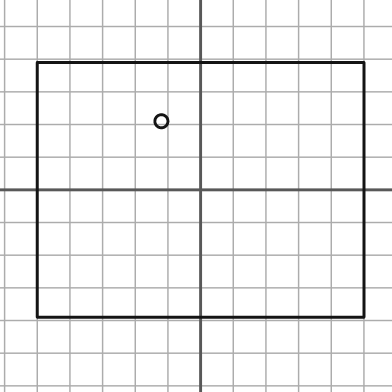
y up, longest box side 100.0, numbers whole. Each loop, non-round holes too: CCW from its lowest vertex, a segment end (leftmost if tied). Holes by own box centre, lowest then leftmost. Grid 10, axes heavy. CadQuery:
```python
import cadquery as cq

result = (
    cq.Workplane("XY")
    .moveTo(-50.0, -39.0)
    .lineTo(50.0, -39.0)
    .lineTo(50.0, 39.0)
    .lineTo(-50.0, 39.0)
    .close()
    .moveTo(-12.0, 21.0)
    .circle(2.0)
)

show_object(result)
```